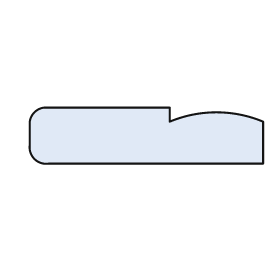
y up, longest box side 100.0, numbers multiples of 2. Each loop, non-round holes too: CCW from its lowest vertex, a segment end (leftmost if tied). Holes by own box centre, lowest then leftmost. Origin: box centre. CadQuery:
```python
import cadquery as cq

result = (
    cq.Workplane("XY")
    .moveTo(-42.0, -12.0)
    .lineTo(50.0, -12.0)
    .lineTo(50.0, 6.0)
    .threePointArc((30.0, 10.0), (10.0, 6.0))
    .lineTo(10.0, 12.0)
    .lineTo(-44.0, 12.0)
    .threePointArc((-48.0, 10.0), (-50.0, 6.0))
    .lineTo(-50.0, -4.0)
    .threePointArc((-48.0, -10.0), (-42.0, -12.0))
    .close()
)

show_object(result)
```